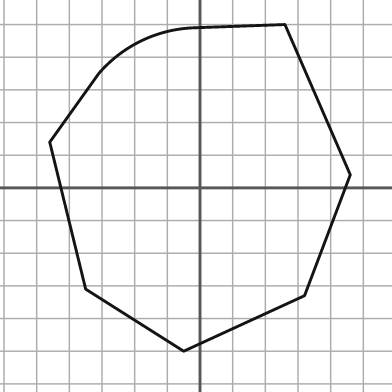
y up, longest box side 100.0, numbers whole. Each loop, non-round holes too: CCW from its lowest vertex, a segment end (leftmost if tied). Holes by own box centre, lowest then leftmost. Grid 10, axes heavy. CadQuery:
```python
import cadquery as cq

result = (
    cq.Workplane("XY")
    .moveTo(-5.0, -50.0)
    .lineTo(32.0, -33.0)
    .lineTo(46.0, 4.0)
    .lineTo(26.0, 50.0)
    .lineTo(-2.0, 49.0)
    .threePointArc((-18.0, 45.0), (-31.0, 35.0))
    .lineTo(-46.0, 14.0)
    .lineTo(-35.0, -31.0)
    .close()
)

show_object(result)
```